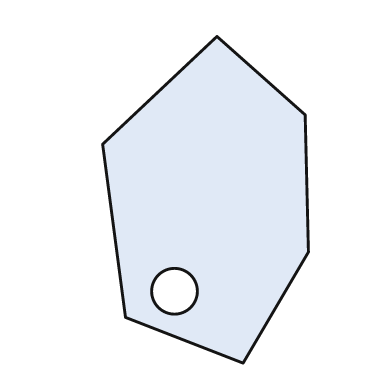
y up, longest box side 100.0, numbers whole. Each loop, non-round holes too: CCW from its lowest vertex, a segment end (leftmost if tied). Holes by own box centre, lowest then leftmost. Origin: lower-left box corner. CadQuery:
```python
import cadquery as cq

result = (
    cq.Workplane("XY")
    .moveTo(43.0, 0.0)
    .lineTo(63.0, 34.0)
    .lineTo(62.0, 76.0)
    .lineTo(35.0, 100.0)
    .lineTo(0.0, 67.0)
    .lineTo(7.0, 14.0)
    .close()
    .moveTo(22.0, 22.0)
    .circle(7.0)
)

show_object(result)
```